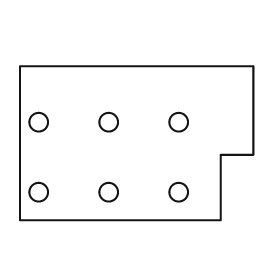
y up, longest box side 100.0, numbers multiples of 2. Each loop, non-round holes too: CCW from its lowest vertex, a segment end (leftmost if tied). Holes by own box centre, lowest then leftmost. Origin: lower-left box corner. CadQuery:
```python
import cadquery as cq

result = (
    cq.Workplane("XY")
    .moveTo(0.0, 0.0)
    .lineTo(86.0, 0.0)
    .lineTo(86.0, 28.0)
    .lineTo(100.0, 28.0)
    .lineTo(100.0, 66.0)
    .lineTo(0.0, 66.0)
    .close()
    .moveTo(8.0, 12.0)
    .circle(4.0)
    .moveTo(38.0, 12.0)
    .circle(4.0)
    .moveTo(68.0, 12.0)
    .circle(4.0)
    .moveTo(8.0, 42.0)
    .circle(4.0)
    .moveTo(38.0, 42.0)
    .circle(4.0)
    .moveTo(68.0, 42.0)
    .circle(4.0)
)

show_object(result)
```